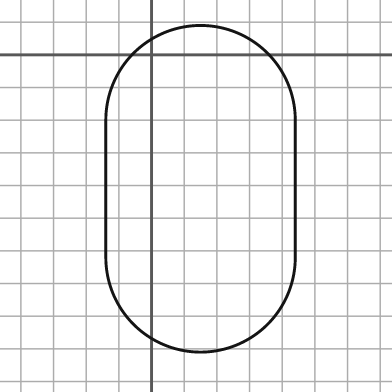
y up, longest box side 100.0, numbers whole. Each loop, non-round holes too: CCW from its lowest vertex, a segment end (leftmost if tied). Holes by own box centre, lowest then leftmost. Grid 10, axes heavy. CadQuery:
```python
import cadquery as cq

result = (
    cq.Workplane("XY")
    .moveTo(-14.0, -62.0)
    .threePointArc((15.0, -91.0), (44.0, -62.0))
    .lineTo(44.0, -20.0)
    .threePointArc((15.0, 9.0), (-14.0, -20.0))
    .close()
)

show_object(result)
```